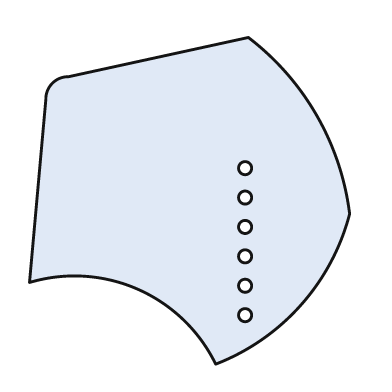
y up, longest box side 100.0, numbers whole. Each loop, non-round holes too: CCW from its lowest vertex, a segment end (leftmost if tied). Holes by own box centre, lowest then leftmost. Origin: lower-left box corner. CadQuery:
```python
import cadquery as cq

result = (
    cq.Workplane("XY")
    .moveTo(57.0, 0.0)
    .threePointArc((83.0, 18.0), (98.0, 46.0))
    .threePointArc((88.0, 76.0), (67.0, 100.0))
    .lineTo(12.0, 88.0)
    .threePointArc((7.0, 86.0), (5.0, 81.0))
    .lineTo(0.0, 25.0)
    .threePointArc((33.0, 23.0), (57.0, 0.0))
    .close()
    .moveTo(66.0, 15.0)
    .circle(2.0)
    .moveTo(66.0, 24.0)
    .circle(2.0)
    .moveTo(66.0, 33.0)
    .circle(2.0)
    .moveTo(66.0, 42.0)
    .circle(2.0)
    .moveTo(66.0, 51.0)
    .circle(2.0)
    .moveTo(66.0, 60.0)
    .circle(2.0)
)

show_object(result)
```